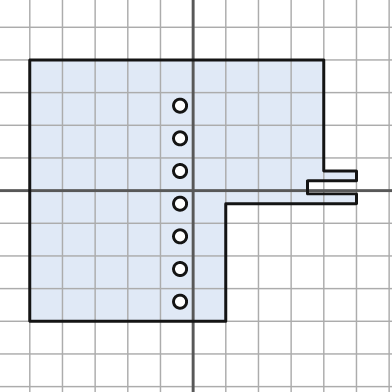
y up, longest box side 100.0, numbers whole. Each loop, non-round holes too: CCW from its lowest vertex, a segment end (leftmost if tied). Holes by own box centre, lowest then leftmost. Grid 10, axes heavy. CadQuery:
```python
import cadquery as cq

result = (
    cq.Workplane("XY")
    .moveTo(-50.0, -40.0)
    .lineTo(10.0, -40.0)
    .lineTo(10.0, -4.0)
    .lineTo(50.0, -4.0)
    .lineTo(50.0, -1.0)
    .lineTo(35.0, -1.0)
    .lineTo(35.0, 3.0)
    .lineTo(50.0, 3.0)
    .lineTo(50.0, 6.0)
    .lineTo(40.0, 6.0)
    .lineTo(40.0, 40.0)
    .lineTo(-50.0, 40.0)
    .close()
    .moveTo(-4.0, -34.0)
    .circle(2.0)
    .moveTo(-4.0, -24.0)
    .circle(2.0)
    .moveTo(-4.0, -14.0)
    .circle(2.0)
    .moveTo(-4.0, -4.0)
    .circle(2.0)
    .moveTo(-4.0, 6.0)
    .circle(2.0)
    .moveTo(-4.0, 16.0)
    .circle(2.0)
    .moveTo(-4.0, 26.0)
    .circle(2.0)
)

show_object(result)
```